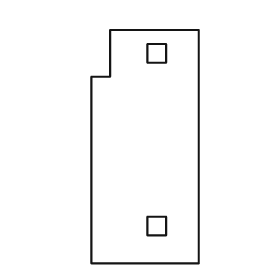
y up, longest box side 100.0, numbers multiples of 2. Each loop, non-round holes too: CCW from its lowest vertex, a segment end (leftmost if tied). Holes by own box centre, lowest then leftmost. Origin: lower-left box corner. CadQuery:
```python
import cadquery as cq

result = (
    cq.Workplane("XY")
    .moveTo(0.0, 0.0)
    .lineTo(46.0, 0.0)
    .lineTo(46.0, 100.0)
    .lineTo(8.0, 100.0)
    .lineTo(8.0, 80.0)
    .lineTo(0.0, 80.0)
    .close()
    .moveTo(24.0, 12.0)
    .lineTo(32.0, 12.0)
    .lineTo(32.0, 20.0)
    .lineTo(24.0, 20.0)
    .close()
    .moveTo(24.0, 86.0)
    .lineTo(32.0, 86.0)
    .lineTo(32.0, 94.0)
    .lineTo(24.0, 94.0)
    .close()
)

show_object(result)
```